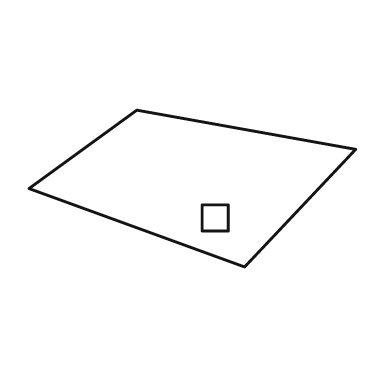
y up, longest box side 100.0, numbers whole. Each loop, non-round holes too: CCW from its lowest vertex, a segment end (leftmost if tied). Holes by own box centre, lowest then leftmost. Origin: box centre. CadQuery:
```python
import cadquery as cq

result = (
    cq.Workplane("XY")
    .moveTo(16.0, -24.0)
    .lineTo(50.0, 12.0)
    .lineTo(-17.0, 24.0)
    .lineTo(-50.0, 0.0)
    .close()
    .moveTo(3.0, -13.0)
    .lineTo(11.0, -13.0)
    .lineTo(11.0, -5.0)
    .lineTo(3.0, -5.0)
    .close()
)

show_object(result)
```